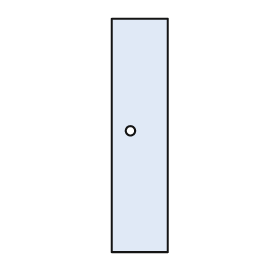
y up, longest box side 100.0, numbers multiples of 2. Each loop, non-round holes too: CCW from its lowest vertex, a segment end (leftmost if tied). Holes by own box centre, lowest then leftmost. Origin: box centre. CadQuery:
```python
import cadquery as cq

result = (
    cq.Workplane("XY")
    .moveTo(-12.0, -50.0)
    .lineTo(12.0, -50.0)
    .lineTo(12.0, 50.0)
    .lineTo(-12.0, 50.0)
    .close()
    .moveTo(-4.0, 2.0)
    .circle(2.0)
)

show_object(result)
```